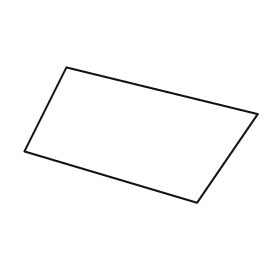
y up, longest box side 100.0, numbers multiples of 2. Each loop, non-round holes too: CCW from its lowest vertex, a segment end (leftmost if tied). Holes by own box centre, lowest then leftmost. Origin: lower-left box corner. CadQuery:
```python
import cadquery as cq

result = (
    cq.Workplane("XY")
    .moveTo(74.0, 0.0)
    .lineTo(100.0, 38.0)
    .lineTo(18.0, 58.0)
    .lineTo(0.0, 22.0)
    .close()
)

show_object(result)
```